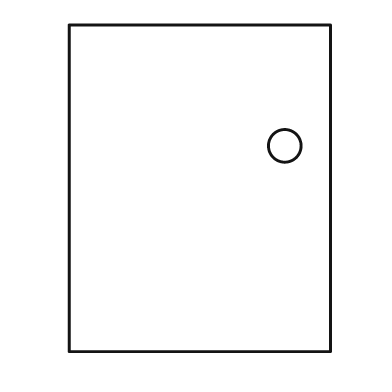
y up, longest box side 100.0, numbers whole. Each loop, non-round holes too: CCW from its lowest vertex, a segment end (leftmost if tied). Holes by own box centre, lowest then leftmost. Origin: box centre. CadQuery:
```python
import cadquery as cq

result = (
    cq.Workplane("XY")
    .moveTo(-40.0, -50.0)
    .lineTo(40.0, -50.0)
    .lineTo(40.0, 50.0)
    .lineTo(-40.0, 50.0)
    .close()
    .moveTo(26.0, 13.0)
    .circle(5.0)
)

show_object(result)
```